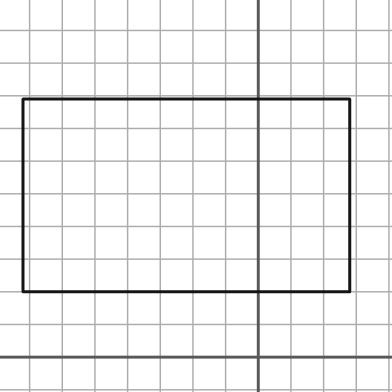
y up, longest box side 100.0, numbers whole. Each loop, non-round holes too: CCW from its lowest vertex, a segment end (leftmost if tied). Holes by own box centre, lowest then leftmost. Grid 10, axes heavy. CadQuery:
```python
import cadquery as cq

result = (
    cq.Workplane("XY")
    .moveTo(-72.0, 20.0)
    .lineTo(28.0, 20.0)
    .lineTo(28.0, 79.0)
    .lineTo(-72.0, 79.0)
    .close()
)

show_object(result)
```